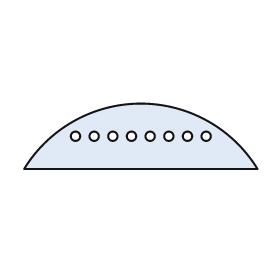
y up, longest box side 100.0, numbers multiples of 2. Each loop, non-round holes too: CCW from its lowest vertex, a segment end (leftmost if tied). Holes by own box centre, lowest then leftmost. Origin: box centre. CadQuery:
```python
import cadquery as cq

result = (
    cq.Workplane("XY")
    .moveTo(-50.0, -14.0)
    .lineTo(50.0, -14.0)
    .threePointArc((0.0, 14.0), (-50.0, -14.0))
    .close()
    .moveTo(-28.0, 0.0)
    .circle(2.0)
    .moveTo(-20.0, 0.0)
    .circle(2.0)
    .moveTo(-12.0, 0.0)
    .circle(2.0)
    .moveTo(-4.0, 0.0)
    .circle(2.0)
    .moveTo(4.0, 0.0)
    .circle(2.0)
    .moveTo(12.0, 0.0)
    .circle(2.0)
    .moveTo(20.0, 0.0)
    .circle(2.0)
    .moveTo(28.0, 0.0)
    .circle(2.0)
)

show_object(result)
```